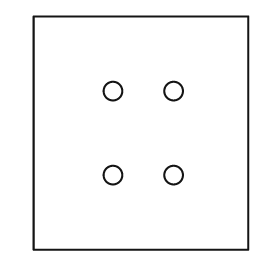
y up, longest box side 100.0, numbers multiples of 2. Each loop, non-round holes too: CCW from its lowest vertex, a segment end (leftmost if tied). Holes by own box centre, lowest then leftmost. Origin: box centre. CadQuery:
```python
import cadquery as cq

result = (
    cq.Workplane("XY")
    .moveTo(-46.0, -50.0)
    .lineTo(46.0, -50.0)
    .lineTo(46.0, 50.0)
    .lineTo(-46.0, 50.0)
    .close()
    .moveTo(-12.0, -18.0)
    .circle(4.0)
    .moveTo(14.0, -18.0)
    .circle(4.0)
    .moveTo(-12.0, 18.0)
    .circle(4.0)
    .moveTo(14.0, 18.0)
    .circle(4.0)
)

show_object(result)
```